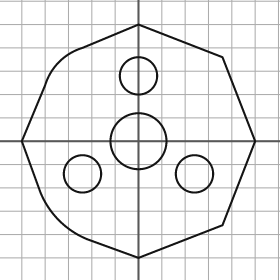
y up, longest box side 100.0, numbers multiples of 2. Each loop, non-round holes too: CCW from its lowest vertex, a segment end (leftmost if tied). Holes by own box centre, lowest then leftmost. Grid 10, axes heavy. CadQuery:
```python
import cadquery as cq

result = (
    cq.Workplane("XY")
    .moveTo(0.0, -50.0)
    .lineTo(36.0, -36.0)
    .lineTo(50.0, 0.0)
    .lineTo(36.0, 36.0)
    .lineTo(0.0, 50.0)
    .lineTo(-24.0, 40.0)
    .threePointArc((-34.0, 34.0), (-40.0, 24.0))
    .lineTo(-50.0, 0.0)
    .lineTo(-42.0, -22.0)
    .threePointArc((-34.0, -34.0), (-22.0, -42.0))
    .close()
    .moveTo(-24.0, -14.0)
    .circle(8.0)
    .moveTo(24.0, -14.0)
    .circle(8.0)
    .moveTo(0.0, 0.0)
    .circle(12.0)
    .moveTo(0.0, 28.0)
    .circle(8.0)
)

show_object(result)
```